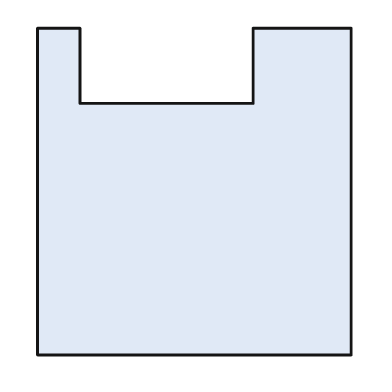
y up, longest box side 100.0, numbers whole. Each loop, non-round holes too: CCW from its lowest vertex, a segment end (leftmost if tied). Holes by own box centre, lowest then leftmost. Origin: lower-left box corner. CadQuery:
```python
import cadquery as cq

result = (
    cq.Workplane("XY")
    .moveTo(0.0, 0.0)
    .lineTo(96.0, 0.0)
    .lineTo(96.0, 100.0)
    .lineTo(66.0, 100.0)
    .lineTo(66.0, 77.0)
    .lineTo(13.0, 77.0)
    .lineTo(13.0, 100.0)
    .lineTo(0.0, 100.0)
    .close()
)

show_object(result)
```